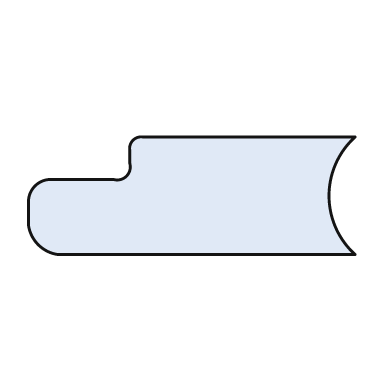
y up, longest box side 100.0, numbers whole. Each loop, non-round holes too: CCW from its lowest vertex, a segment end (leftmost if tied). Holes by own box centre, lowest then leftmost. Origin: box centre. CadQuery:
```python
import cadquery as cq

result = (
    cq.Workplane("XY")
    .moveTo(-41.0, -18.0)
    .lineTo(50.0, -18.0)
    .threePointArc((42.0, 0.0), (50.0, 18.0))
    .lineTo(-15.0, 18.0)
    .threePointArc((-18.0, 17.0), (-19.0, 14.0))
    .lineTo(-19.0, 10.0)
    .threePointArc((-20.0, 6.0), (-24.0, 5.0))
    .lineTo(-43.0, 5.0)
    .threePointArc((-48.0, 3.0), (-50.0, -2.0))
    .lineTo(-50.0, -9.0)
    .threePointArc((-47.0, -15.0), (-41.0, -18.0))
    .close()
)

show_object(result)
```